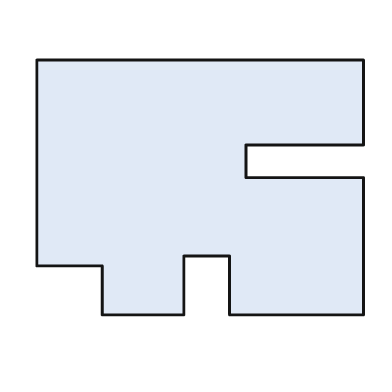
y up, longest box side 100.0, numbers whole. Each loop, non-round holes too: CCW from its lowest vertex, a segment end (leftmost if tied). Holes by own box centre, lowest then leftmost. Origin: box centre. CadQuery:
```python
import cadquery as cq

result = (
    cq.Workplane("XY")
    .moveTo(-30.0, -39.0)
    .lineTo(-5.0, -39.0)
    .lineTo(-5.0, -21.0)
    .lineTo(9.0, -21.0)
    .lineTo(9.0, -39.0)
    .lineTo(50.0, -39.0)
    .lineTo(50.0, 3.0)
    .lineTo(14.0, 3.0)
    .lineTo(14.0, 13.0)
    .lineTo(50.0, 13.0)
    .lineTo(50.0, 39.0)
    .lineTo(-50.0, 39.0)
    .lineTo(-50.0, -24.0)
    .lineTo(-30.0, -24.0)
    .close()
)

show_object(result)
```